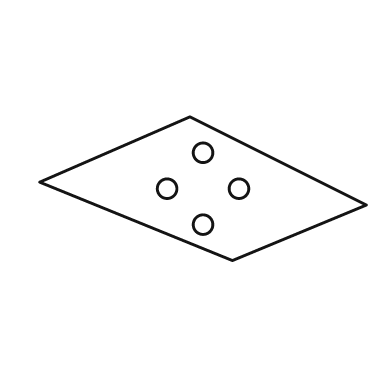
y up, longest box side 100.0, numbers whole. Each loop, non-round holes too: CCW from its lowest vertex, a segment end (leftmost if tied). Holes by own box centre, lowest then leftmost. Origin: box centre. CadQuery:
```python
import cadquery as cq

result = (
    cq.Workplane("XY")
    .moveTo(9.0, -22.0)
    .lineTo(50.0, -5.0)
    .lineTo(-4.0, 22.0)
    .lineTo(-50.0, 2.0)
    .close()
    .moveTo(0.0, -11.0)
    .circle(3.0)
    .moveTo(-11.0, 0.0)
    .circle(3.0)
    .moveTo(11.0, 0.0)
    .circle(3.0)
    .moveTo(0.0, 11.0)
    .circle(3.0)
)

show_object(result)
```